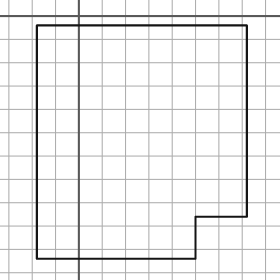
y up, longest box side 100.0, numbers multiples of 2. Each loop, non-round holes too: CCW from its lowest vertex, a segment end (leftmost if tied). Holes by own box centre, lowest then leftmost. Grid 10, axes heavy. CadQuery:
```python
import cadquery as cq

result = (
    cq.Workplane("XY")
    .moveTo(-18.0, -104.0)
    .lineTo(50.0, -104.0)
    .lineTo(50.0, -86.0)
    .lineTo(72.0, -86.0)
    .lineTo(72.0, -4.0)
    .lineTo(-18.0, -4.0)
    .close()
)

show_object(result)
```